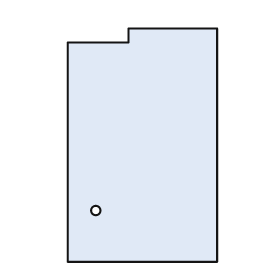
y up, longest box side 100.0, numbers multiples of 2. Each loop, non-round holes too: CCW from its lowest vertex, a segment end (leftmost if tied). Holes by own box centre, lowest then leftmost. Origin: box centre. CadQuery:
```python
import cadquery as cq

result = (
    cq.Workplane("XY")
    .moveTo(-32.0, -50.0)
    .lineTo(32.0, -50.0)
    .lineTo(32.0, 50.0)
    .lineTo(-6.0, 50.0)
    .lineTo(-6.0, 44.0)
    .lineTo(-32.0, 44.0)
    .close()
    .moveTo(-20.0, -28.0)
    .circle(2.0)
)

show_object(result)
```